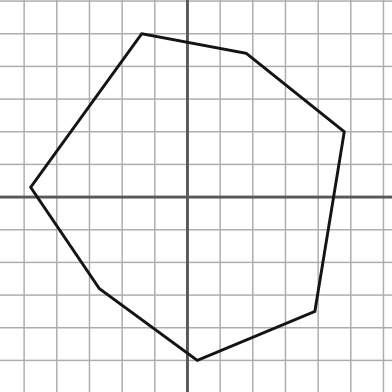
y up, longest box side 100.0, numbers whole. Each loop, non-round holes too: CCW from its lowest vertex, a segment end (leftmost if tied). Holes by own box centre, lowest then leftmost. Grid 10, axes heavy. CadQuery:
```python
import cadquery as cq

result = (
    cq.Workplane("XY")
    .moveTo(3.0, -50.0)
    .lineTo(39.0, -35.0)
    .lineTo(48.0, 20.0)
    .lineTo(18.0, 44.0)
    .lineTo(-14.0, 50.0)
    .lineTo(-48.0, 3.0)
    .lineTo(-27.0, -28.0)
    .close()
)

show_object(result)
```